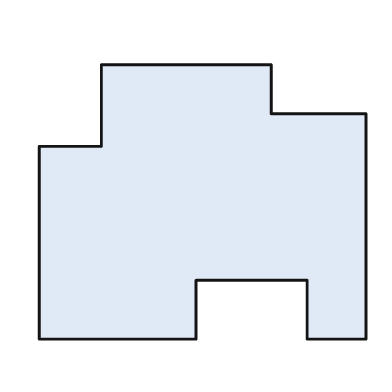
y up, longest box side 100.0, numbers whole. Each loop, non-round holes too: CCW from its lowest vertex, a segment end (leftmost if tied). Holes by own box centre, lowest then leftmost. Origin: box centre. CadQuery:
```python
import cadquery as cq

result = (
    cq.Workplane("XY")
    .moveTo(-50.0, -42.0)
    .lineTo(-2.0, -42.0)
    .lineTo(-2.0, -24.0)
    .lineTo(32.0, -24.0)
    .lineTo(32.0, -42.0)
    .lineTo(50.0, -42.0)
    .lineTo(50.0, 27.0)
    .lineTo(21.0, 27.0)
    .lineTo(21.0, 42.0)
    .lineTo(-31.0, 42.0)
    .lineTo(-31.0, 17.0)
    .lineTo(-50.0, 17.0)
    .close()
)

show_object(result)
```